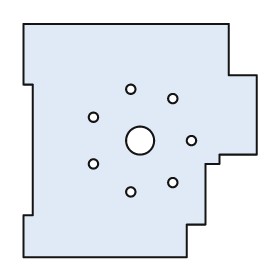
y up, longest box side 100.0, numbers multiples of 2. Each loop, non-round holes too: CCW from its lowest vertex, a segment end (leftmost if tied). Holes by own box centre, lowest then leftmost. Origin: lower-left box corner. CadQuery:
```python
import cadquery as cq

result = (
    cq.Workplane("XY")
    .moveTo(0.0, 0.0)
    .lineTo(70.0, 0.0)
    .lineTo(70.0, 14.0)
    .lineTo(78.0, 14.0)
    .lineTo(78.0, 40.0)
    .lineTo(84.0, 40.0)
    .lineTo(84.0, 44.0)
    .lineTo(100.0, 44.0)
    .lineTo(100.0, 78.0)
    .lineTo(88.0, 78.0)
    .lineTo(88.0, 100.0)
    .lineTo(0.0, 100.0)
    .lineTo(0.0, 74.0)
    .lineTo(4.0, 74.0)
    .lineTo(4.0, 18.0)
    .lineTo(0.0, 18.0)
    .close()
    .moveTo(46.0, 28.0)
    .circle(2.0)
    .moveTo(64.0, 32.0)
    .circle(2.0)
    .moveTo(30.0, 40.0)
    .circle(2.0)
    .moveTo(50.0, 50.0)
    .circle(6.0)
    .moveTo(72.0, 50.0)
    .circle(2.0)
    .moveTo(30.0, 60.0)
    .circle(2.0)
    .moveTo(64.0, 68.0)
    .circle(2.0)
    .moveTo(46.0, 72.0)
    .circle(2.0)
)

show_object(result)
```